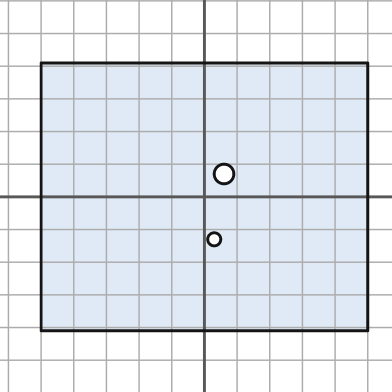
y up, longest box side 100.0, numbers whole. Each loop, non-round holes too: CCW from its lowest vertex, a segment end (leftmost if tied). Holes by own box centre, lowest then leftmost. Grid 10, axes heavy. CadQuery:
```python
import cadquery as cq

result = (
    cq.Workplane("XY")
    .moveTo(-50.0, -41.0)
    .lineTo(50.0, -41.0)
    .lineTo(50.0, 41.0)
    .lineTo(-50.0, 41.0)
    .close()
    .moveTo(3.0, -13.0)
    .circle(2.0)
    .moveTo(6.0, 7.0)
    .circle(3.0)
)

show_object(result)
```